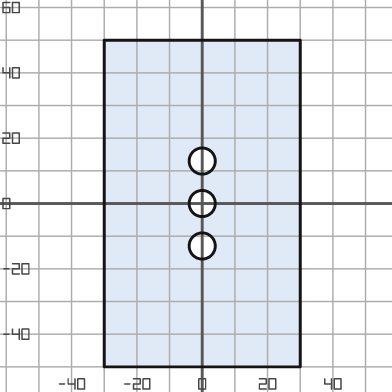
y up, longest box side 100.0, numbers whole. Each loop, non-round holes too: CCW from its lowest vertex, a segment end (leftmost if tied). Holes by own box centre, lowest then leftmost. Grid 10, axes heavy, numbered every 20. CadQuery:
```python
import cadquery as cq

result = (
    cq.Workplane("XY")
    .moveTo(-30.0, -50.0)
    .lineTo(30.0, -50.0)
    .lineTo(30.0, 50.0)
    .lineTo(-30.0, 50.0)
    .close()
    .moveTo(0.0, -13.0)
    .circle(4.0)
    .moveTo(0.0, 0.0)
    .circle(4.0)
    .moveTo(0.0, 13.0)
    .circle(4.0)
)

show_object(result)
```